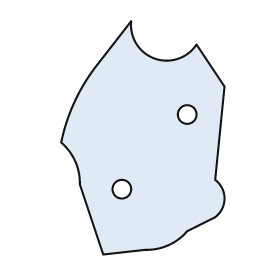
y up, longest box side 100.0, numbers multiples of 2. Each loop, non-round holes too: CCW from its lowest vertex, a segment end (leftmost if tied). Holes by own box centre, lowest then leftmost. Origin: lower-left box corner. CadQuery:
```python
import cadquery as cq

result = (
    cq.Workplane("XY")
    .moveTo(18.0, 0.0)
    .lineTo(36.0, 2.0)
    .threePointArc((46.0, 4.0), (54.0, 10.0))
    .lineTo(66.0, 16.0)
    .threePointArc((70.0, 24.0), (66.0, 32.0))
    .lineTo(70.0, 72.0)
    .lineTo(58.0, 90.0)
    .threePointArc((40.0, 84.0), (30.0, 100.0))
    .lineTo(16.0, 82.0)
    .threePointArc((6.0, 66.0), (0.0, 48.0))
    .threePointArc((6.0, 40.0), (8.0, 30.0))
    .close()
    .moveTo(26.0, 28.0)
    .circle(4.0)
    .moveTo(54.0, 60.0)
    .circle(4.0)
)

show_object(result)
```